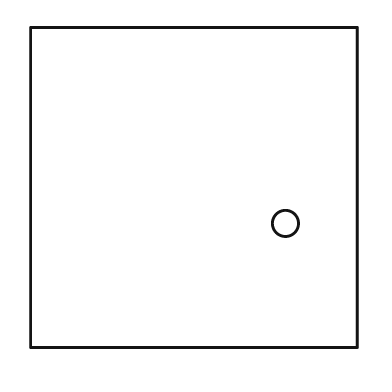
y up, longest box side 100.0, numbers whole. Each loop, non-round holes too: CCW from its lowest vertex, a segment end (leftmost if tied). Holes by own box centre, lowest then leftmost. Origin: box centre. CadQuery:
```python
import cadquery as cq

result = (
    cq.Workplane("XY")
    .moveTo(-50.0, -49.0)
    .lineTo(50.0, -49.0)
    .lineTo(50.0, 49.0)
    .lineTo(-50.0, 49.0)
    .close()
    .moveTo(28.0, -11.0)
    .circle(4.0)
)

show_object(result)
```